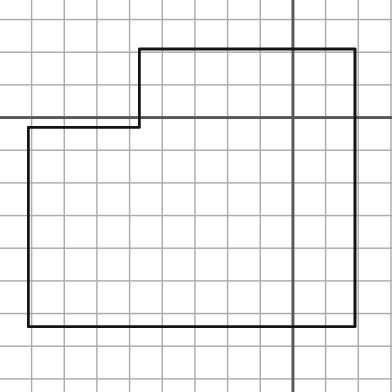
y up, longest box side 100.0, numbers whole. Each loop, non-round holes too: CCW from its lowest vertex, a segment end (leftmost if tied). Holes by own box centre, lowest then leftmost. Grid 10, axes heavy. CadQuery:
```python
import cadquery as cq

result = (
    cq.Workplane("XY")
    .moveTo(-81.0, -64.0)
    .lineTo(19.0, -64.0)
    .lineTo(19.0, 21.0)
    .lineTo(-47.0, 21.0)
    .lineTo(-47.0, -3.0)
    .lineTo(-81.0, -3.0)
    .close()
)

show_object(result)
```